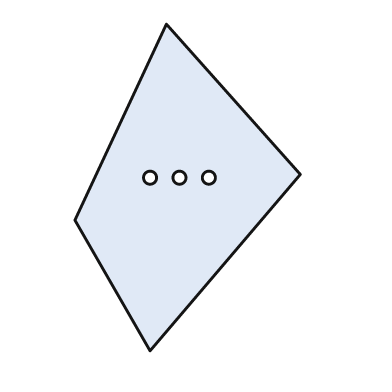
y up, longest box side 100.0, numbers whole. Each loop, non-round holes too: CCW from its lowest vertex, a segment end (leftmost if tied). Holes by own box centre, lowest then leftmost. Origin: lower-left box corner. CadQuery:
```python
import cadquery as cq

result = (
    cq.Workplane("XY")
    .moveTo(23.0, 0.0)
    .lineTo(69.0, 54.0)
    .lineTo(28.0, 100.0)
    .lineTo(0.0, 40.0)
    .close()
    .moveTo(23.0, 53.0)
    .circle(2.0)
    .moveTo(32.0, 53.0)
    .circle(2.0)
    .moveTo(41.0, 53.0)
    .circle(2.0)
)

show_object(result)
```